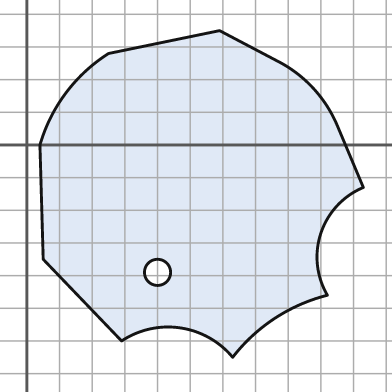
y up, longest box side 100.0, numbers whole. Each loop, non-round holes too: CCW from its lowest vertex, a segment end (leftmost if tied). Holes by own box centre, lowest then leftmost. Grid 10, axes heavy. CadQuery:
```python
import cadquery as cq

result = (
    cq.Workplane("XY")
    .moveTo(63.0, -65.0)
    .threePointArc((76.0, -53.0), (92.0, -46.0))
    .threePointArc((90.0, -27.0), (103.0, -13.0))
    .lineTo(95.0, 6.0)
    .threePointArc((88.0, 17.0), (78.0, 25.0))
    .lineTo(59.0, 35.0)
    .lineTo(25.0, 28.0)
    .threePointArc((12.0, 16.0), (4.0, 0.0))
    .lineTo(5.0, -35.0)
    .lineTo(29.0, -60.0)
    .threePointArc((47.0, -56.0), (63.0, -65.0))
    .close()
    .moveTo(40.0, -39.0)
    .circle(4.0)
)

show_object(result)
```